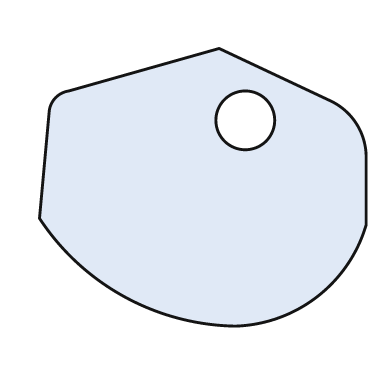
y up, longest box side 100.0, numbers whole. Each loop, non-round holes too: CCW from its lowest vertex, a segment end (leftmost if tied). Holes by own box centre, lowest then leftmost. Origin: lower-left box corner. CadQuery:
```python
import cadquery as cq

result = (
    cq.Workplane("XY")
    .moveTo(60.0, 0.0)
    .threePointArc((85.0, 9.0), (100.0, 31.0))
    .lineTo(100.0, 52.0)
    .threePointArc((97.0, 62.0), (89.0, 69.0))
    .lineTo(55.0, 85.0)
    .lineTo(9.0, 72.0)
    .threePointArc((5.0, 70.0), (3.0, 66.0))
    .lineTo(0.0, 33.0)
    .threePointArc((26.0, 9.0), (60.0, 0.0))
    .close()
    .moveTo(63.0, 63.0)
    .circle(9.0)
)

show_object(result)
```